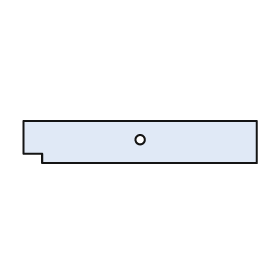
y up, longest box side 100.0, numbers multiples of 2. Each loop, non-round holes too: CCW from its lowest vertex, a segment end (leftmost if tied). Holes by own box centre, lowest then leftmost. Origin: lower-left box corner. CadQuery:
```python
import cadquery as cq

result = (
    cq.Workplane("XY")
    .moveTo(8.0, 0.0)
    .lineTo(100.0, 0.0)
    .lineTo(100.0, 18.0)
    .lineTo(0.0, 18.0)
    .lineTo(0.0, 4.0)
    .lineTo(8.0, 4.0)
    .close()
    .moveTo(50.0, 10.0)
    .circle(2.0)
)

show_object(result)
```